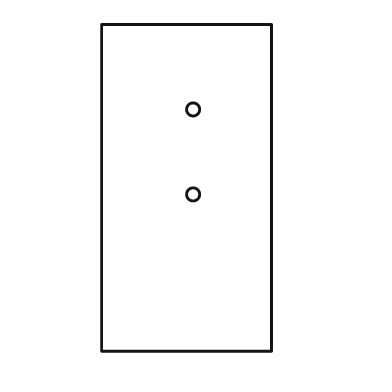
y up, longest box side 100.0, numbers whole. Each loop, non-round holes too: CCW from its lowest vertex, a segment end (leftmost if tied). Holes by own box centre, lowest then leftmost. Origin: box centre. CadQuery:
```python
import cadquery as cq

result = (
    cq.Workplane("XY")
    .moveTo(-26.0, -50.0)
    .lineTo(26.0, -50.0)
    .lineTo(26.0, 50.0)
    .lineTo(-26.0, 50.0)
    .close()
    .moveTo(2.0, -2.0)
    .circle(2.0)
    .moveTo(2.0, 24.0)
    .circle(2.0)
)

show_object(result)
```